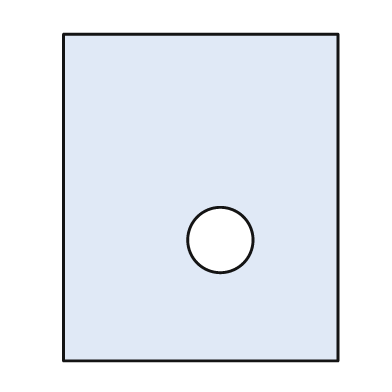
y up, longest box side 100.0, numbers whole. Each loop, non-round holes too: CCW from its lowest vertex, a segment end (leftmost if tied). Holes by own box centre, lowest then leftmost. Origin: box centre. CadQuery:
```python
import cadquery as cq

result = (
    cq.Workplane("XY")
    .moveTo(-42.0, -50.0)
    .lineTo(42.0, -50.0)
    .lineTo(42.0, 50.0)
    .lineTo(-42.0, 50.0)
    .close()
    .moveTo(6.0, -13.0)
    .circle(10.0)
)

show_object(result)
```